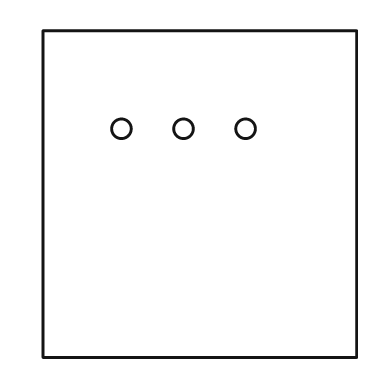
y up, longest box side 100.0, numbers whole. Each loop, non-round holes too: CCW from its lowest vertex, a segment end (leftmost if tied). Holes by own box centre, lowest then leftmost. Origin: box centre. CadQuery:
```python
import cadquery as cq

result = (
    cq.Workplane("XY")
    .moveTo(-48.0, -50.0)
    .lineTo(48.0, -50.0)
    .lineTo(48.0, 50.0)
    .lineTo(-48.0, 50.0)
    .close()
    .moveTo(-24.0, 20.0)
    .circle(3.0)
    .moveTo(-5.0, 20.0)
    .circle(3.0)
    .moveTo(14.0, 20.0)
    .circle(3.0)
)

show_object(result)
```